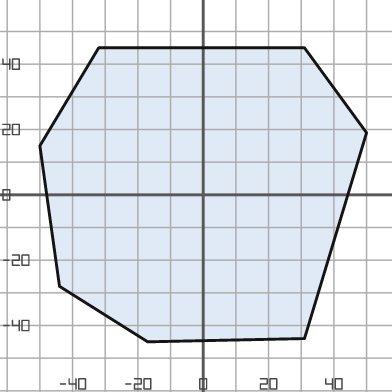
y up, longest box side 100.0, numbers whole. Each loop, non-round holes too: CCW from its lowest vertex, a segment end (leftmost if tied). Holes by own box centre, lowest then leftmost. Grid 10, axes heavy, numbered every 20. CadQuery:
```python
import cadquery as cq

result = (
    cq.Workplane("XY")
    .moveTo(-17.0, -45.0)
    .lineTo(31.0, -44.0)
    .lineTo(50.0, 19.0)
    .lineTo(31.0, 45.0)
    .lineTo(-32.0, 45.0)
    .lineTo(-50.0, 15.0)
    .lineTo(-44.0, -28.0)
    .close()
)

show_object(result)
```